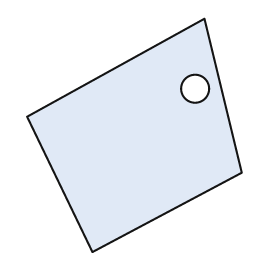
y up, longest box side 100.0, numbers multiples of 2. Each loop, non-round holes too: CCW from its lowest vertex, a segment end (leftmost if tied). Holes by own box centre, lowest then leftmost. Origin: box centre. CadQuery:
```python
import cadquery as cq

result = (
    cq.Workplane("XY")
    .moveTo(-18.0, -50.0)
    .lineTo(46.0, -16.0)
    .lineTo(30.0, 50.0)
    .lineTo(-46.0, 8.0)
    .close()
    .moveTo(26.0, 20.0)
    .circle(6.0)
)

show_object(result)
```